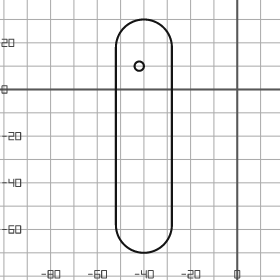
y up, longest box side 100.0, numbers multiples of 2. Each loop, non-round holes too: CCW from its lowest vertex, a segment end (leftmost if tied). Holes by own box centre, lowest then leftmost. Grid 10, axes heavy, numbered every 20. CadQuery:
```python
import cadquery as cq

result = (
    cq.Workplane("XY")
    .moveTo(-52.0, -58.0)
    .threePointArc((-40.0, -70.0), (-28.0, -58.0))
    .lineTo(-28.0, 18.0)
    .threePointArc((-40.0, 30.0), (-52.0, 18.0))
    .close()
    .moveTo(-42.0, 10.0)
    .circle(2.0)
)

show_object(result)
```